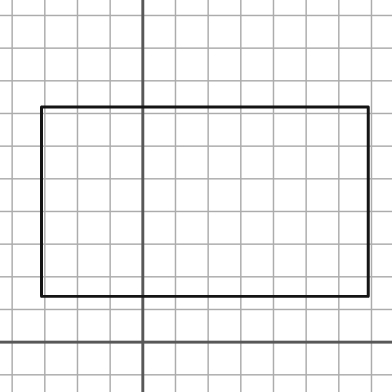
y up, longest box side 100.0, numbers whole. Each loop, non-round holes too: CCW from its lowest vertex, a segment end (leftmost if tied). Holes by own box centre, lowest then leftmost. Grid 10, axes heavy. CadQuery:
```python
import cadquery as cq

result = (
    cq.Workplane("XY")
    .moveTo(-31.0, 14.0)
    .lineTo(69.0, 14.0)
    .lineTo(69.0, 72.0)
    .lineTo(-31.0, 72.0)
    .close()
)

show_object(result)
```